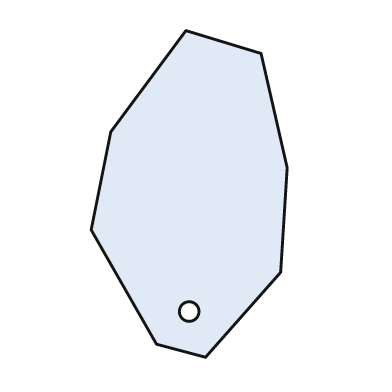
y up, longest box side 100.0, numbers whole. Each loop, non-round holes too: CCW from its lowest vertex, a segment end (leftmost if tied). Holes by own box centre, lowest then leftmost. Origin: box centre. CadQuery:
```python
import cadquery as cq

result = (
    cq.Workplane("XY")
    .moveTo(5.0, -50.0)
    .lineTo(28.0, -24.0)
    .lineTo(30.0, 8.0)
    .lineTo(22.0, 43.0)
    .lineTo(-1.0, 50.0)
    .lineTo(-24.0, 19.0)
    .lineTo(-30.0, -11.0)
    .lineTo(-10.0, -46.0)
    .close()
    .moveTo(0.0, -36.0)
    .circle(3.0)
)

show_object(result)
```